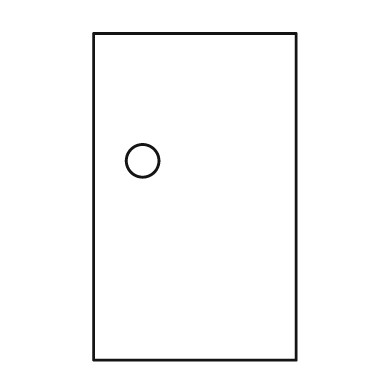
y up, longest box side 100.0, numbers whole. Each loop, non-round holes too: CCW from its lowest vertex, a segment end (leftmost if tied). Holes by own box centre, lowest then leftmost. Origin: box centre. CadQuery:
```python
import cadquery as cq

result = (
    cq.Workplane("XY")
    .moveTo(-31.0, -50.0)
    .lineTo(31.0, -50.0)
    .lineTo(31.0, 50.0)
    .lineTo(-31.0, 50.0)
    .close()
    .moveTo(-16.0, 11.0)
    .circle(5.0)
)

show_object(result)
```